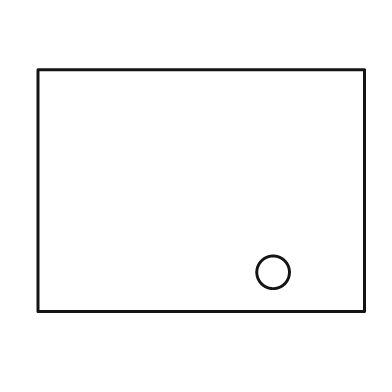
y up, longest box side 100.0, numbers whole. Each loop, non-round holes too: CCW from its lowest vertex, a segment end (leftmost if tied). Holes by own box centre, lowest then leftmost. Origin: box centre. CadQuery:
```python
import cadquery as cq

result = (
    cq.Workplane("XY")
    .moveTo(-50.0, -37.0)
    .lineTo(50.0, -37.0)
    .lineTo(50.0, 37.0)
    .lineTo(-50.0, 37.0)
    .close()
    .moveTo(22.0, -25.0)
    .circle(5.0)
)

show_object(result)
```